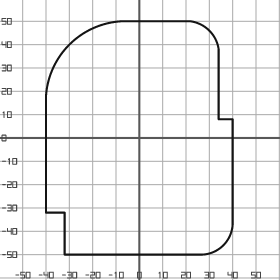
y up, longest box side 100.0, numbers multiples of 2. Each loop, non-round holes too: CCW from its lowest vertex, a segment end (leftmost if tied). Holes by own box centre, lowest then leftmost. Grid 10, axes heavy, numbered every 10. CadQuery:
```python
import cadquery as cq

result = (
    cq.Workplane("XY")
    .moveTo(-32.0, -50.0)
    .lineTo(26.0, -50.0)
    .threePointArc((36.0, -46.0), (40.0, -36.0))
    .lineTo(40.0, 8.0)
    .lineTo(34.0, 8.0)
    .lineTo(34.0, 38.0)
    .threePointArc((30.0, 46.0), (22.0, 50.0))
    .lineTo(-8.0, 50.0)
    .threePointArc((-30.0, 40.0), (-40.0, 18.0))
    .lineTo(-40.0, -32.0)
    .lineTo(-32.0, -32.0)
    .close()
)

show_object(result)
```